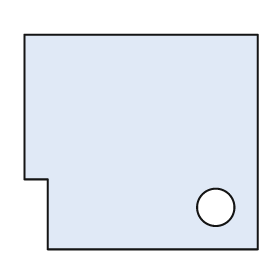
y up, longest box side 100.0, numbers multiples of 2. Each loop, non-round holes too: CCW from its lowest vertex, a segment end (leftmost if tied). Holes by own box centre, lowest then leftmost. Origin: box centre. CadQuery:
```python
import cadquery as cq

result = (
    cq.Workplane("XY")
    .moveTo(-40.0, -46.0)
    .lineTo(50.0, -46.0)
    .lineTo(50.0, 46.0)
    .lineTo(-50.0, 46.0)
    .lineTo(-50.0, -16.0)
    .lineTo(-40.0, -16.0)
    .close()
    .moveTo(32.0, -28.0)
    .circle(8.0)
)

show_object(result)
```